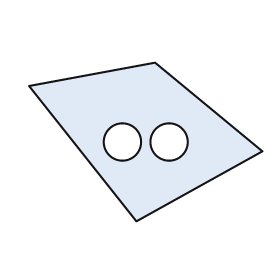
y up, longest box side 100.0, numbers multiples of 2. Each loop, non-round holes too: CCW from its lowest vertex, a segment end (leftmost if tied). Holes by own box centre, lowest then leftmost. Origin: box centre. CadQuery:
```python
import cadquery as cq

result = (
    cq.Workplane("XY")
    .moveTo(-4.0, -34.0)
    .lineTo(50.0, -4.0)
    .lineTo(4.0, 34.0)
    .lineTo(-50.0, 24.0)
    .close()
    .moveTo(-10.0, 0.0)
    .circle(8.0)
    .moveTo(10.0, 0.0)
    .circle(8.0)
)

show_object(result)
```